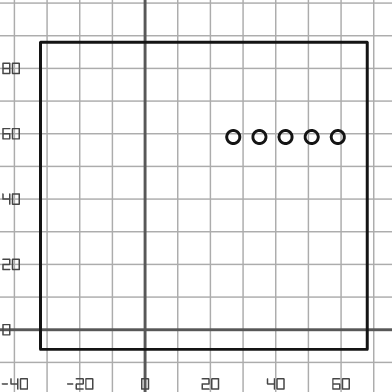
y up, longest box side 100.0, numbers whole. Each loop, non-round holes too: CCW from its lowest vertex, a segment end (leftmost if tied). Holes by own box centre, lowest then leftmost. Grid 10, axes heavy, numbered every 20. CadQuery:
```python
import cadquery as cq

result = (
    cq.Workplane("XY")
    .moveTo(-32.0, -6.0)
    .lineTo(68.0, -6.0)
    .lineTo(68.0, 88.0)
    .lineTo(-32.0, 88.0)
    .close()
    .moveTo(27.0, 59.0)
    .circle(2.0)
    .moveTo(35.0, 59.0)
    .circle(2.0)
    .moveTo(43.0, 59.0)
    .circle(2.0)
    .moveTo(51.0, 59.0)
    .circle(2.0)
    .moveTo(59.0, 59.0)
    .circle(2.0)
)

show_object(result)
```